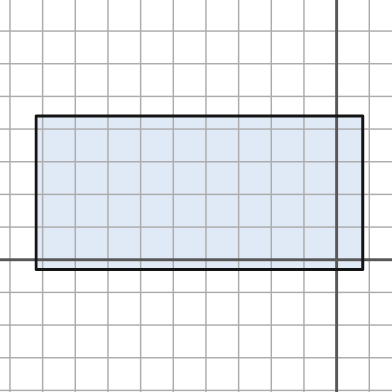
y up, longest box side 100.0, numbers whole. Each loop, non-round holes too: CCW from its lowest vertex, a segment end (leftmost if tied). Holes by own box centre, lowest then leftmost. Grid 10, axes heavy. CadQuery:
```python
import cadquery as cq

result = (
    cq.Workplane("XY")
    .moveTo(-92.0, -3.0)
    .lineTo(8.0, -3.0)
    .lineTo(8.0, 44.0)
    .lineTo(-92.0, 44.0)
    .close()
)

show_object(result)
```